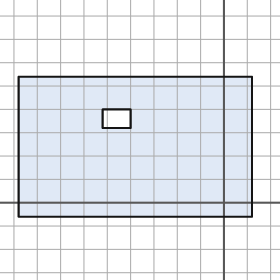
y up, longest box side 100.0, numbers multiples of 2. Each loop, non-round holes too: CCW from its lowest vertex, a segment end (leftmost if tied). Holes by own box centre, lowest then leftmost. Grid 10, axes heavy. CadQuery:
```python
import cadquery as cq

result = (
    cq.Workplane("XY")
    .moveTo(-88.0, -6.0)
    .lineTo(12.0, -6.0)
    .lineTo(12.0, 54.0)
    .lineTo(-88.0, 54.0)
    .close()
    .moveTo(-52.0, 32.0)
    .lineTo(-40.0, 32.0)
    .lineTo(-40.0, 40.0)
    .lineTo(-52.0, 40.0)
    .close()
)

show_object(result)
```